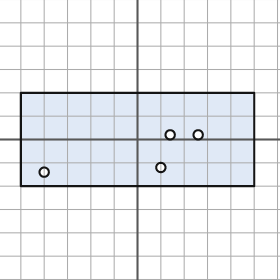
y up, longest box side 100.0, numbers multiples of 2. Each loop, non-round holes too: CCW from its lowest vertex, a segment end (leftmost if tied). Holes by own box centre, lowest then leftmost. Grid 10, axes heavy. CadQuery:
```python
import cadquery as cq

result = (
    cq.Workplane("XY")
    .moveTo(-50.0, -20.0)
    .lineTo(50.0, -20.0)
    .lineTo(50.0, 20.0)
    .lineTo(-50.0, 20.0)
    .close()
    .moveTo(-40.0, -14.0)
    .circle(2.0)
    .moveTo(10.0, -12.0)
    .circle(2.0)
    .moveTo(14.0, 2.0)
    .circle(2.0)
    .moveTo(26.0, 2.0)
    .circle(2.0)
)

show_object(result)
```